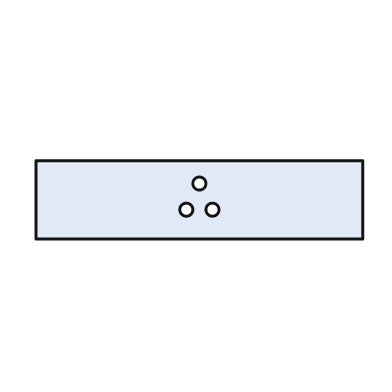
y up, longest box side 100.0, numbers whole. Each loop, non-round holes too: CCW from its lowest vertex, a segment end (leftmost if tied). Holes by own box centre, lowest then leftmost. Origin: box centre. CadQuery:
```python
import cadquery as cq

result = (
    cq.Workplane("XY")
    .moveTo(-50.0, -12.0)
    .lineTo(50.0, -12.0)
    .lineTo(50.0, 12.0)
    .lineTo(-50.0, 12.0)
    .close()
    .moveTo(-4.0, -3.0)
    .circle(2.0)
    .moveTo(4.0, -3.0)
    .circle(2.0)
    .moveTo(0.0, 5.0)
    .circle(2.0)
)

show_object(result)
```